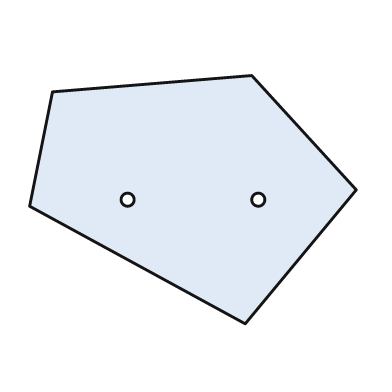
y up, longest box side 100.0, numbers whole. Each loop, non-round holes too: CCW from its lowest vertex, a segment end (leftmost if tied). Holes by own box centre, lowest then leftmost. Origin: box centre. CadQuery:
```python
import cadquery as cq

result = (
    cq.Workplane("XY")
    .moveTo(16.0, -38.0)
    .lineTo(50.0, 3.0)
    .lineTo(18.0, 38.0)
    .lineTo(-43.0, 33.0)
    .lineTo(-50.0, -2.0)
    .close()
    .moveTo(-20.0, 0.0)
    .circle(2.0)
    .moveTo(20.0, 0.0)
    .circle(2.0)
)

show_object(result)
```